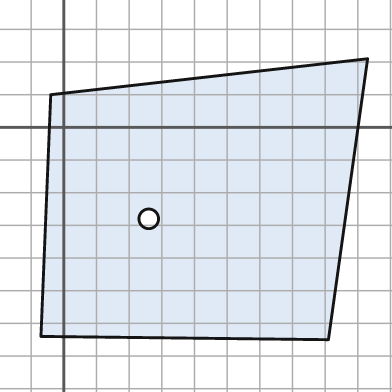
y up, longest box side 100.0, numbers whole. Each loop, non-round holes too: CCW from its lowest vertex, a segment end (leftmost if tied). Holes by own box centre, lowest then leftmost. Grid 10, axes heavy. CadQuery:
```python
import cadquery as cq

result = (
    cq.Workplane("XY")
    .moveTo(81.0, -65.0)
    .lineTo(93.0, 21.0)
    .lineTo(-4.0, 10.0)
    .lineTo(-7.0, -64.0)
    .close()
    .moveTo(26.0, -28.0)
    .circle(3.0)
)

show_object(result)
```